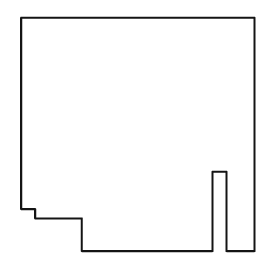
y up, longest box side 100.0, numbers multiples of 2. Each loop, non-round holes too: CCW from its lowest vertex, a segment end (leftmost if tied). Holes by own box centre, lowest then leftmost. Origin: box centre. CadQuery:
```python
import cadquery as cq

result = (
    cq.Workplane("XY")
    .moveTo(-24.0, -50.0)
    .lineTo(32.0, -50.0)
    .lineTo(32.0, -16.0)
    .lineTo(38.0, -16.0)
    .lineTo(38.0, -50.0)
    .lineTo(50.0, -50.0)
    .lineTo(50.0, 50.0)
    .lineTo(-50.0, 50.0)
    .lineTo(-50.0, -32.0)
    .lineTo(-44.0, -32.0)
    .lineTo(-44.0, -36.0)
    .lineTo(-24.0, -36.0)
    .close()
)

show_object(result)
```